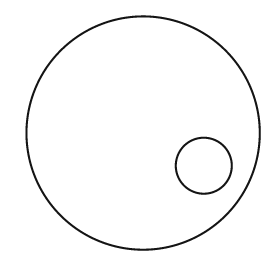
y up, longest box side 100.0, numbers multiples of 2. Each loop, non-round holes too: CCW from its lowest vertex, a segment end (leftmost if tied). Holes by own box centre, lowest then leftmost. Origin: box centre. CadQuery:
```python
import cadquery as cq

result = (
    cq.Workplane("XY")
    .moveTo(0.0, 0.0)
    .circle(50.0)
    .moveTo(26.0, -14.0)
    .circle(12.0)
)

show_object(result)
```